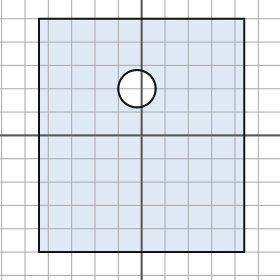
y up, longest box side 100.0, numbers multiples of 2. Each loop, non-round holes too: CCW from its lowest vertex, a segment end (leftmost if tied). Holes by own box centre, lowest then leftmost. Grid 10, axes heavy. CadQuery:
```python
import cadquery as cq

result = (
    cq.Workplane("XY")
    .moveTo(-44.0, -50.0)
    .lineTo(44.0, -50.0)
    .lineTo(44.0, 50.0)
    .lineTo(-44.0, 50.0)
    .close()
    .moveTo(-2.0, 20.0)
    .circle(8.0)
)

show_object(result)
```